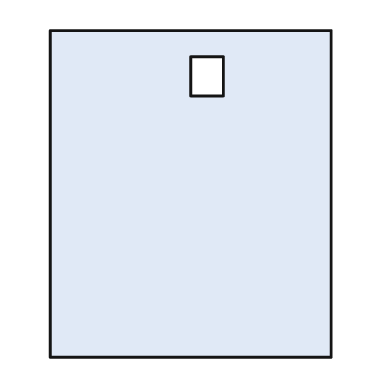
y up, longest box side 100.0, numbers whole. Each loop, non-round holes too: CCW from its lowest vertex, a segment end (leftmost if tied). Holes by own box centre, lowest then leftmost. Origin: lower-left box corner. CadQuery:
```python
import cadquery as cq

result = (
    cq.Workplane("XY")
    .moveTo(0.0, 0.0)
    .lineTo(86.0, 0.0)
    .lineTo(86.0, 100.0)
    .lineTo(0.0, 100.0)
    .close()
    .moveTo(43.0, 80.0)
    .lineTo(53.0, 80.0)
    .lineTo(53.0, 92.0)
    .lineTo(43.0, 92.0)
    .close()
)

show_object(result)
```